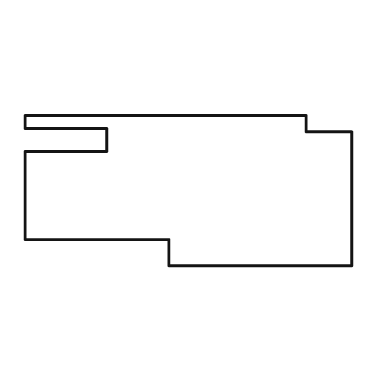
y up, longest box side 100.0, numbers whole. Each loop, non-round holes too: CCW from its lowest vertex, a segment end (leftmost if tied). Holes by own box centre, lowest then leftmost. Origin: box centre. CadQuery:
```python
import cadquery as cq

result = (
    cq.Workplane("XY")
    .moveTo(-6.0, -23.0)
    .lineTo(50.0, -23.0)
    .lineTo(50.0, 18.0)
    .lineTo(36.0, 18.0)
    .lineTo(36.0, 23.0)
    .lineTo(-50.0, 23.0)
    .lineTo(-50.0, 19.0)
    .lineTo(-25.0, 19.0)
    .lineTo(-25.0, 12.0)
    .lineTo(-50.0, 12.0)
    .lineTo(-50.0, -15.0)
    .lineTo(-6.0, -15.0)
    .close()
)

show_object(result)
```